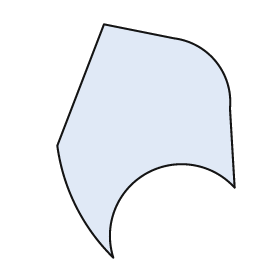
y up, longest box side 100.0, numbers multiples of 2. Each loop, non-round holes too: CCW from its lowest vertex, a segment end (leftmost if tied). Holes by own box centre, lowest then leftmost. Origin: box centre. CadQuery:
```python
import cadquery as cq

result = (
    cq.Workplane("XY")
    .moveTo(-14.0, -50.0)
    .threePointArc((0.0, -14.0), (38.0, -20.0))
    .lineTo(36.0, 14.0)
    .threePointArc((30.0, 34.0), (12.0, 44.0))
    .lineTo(-18.0, 50.0)
    .lineTo(-38.0, -2.0)
    .threePointArc((-30.0, -28.0), (-14.0, -50.0))
    .close()
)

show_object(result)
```